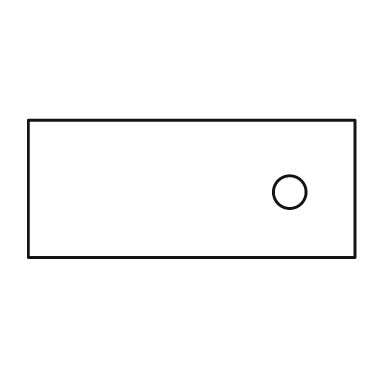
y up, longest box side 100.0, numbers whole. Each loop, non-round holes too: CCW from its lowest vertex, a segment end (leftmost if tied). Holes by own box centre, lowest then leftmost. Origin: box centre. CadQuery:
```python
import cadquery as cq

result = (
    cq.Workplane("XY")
    .moveTo(-50.0, -21.0)
    .lineTo(50.0, -21.0)
    .lineTo(50.0, 21.0)
    .lineTo(-50.0, 21.0)
    .close()
    .moveTo(30.0, -1.0)
    .circle(5.0)
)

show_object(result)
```